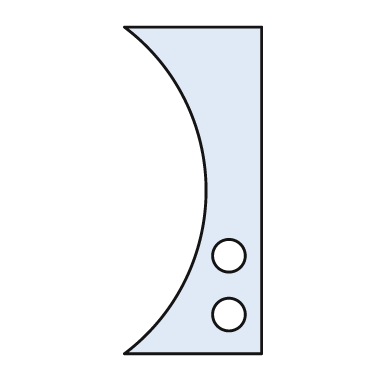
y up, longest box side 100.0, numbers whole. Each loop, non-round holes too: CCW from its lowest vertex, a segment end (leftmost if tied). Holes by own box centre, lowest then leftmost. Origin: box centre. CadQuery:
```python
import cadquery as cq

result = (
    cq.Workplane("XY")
    .moveTo(-21.0, -50.0)
    .lineTo(21.0, -50.0)
    .lineTo(21.0, 50.0)
    .lineTo(-21.0, 50.0)
    .threePointArc((4.0, 0.0), (-21.0, -50.0))
    .close()
    .moveTo(11.0, -38.0)
    .circle(5.0)
    .moveTo(11.0, -20.0)
    .circle(5.0)
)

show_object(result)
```